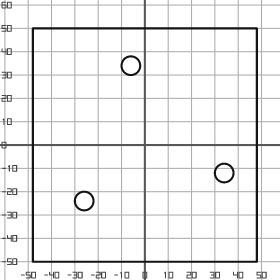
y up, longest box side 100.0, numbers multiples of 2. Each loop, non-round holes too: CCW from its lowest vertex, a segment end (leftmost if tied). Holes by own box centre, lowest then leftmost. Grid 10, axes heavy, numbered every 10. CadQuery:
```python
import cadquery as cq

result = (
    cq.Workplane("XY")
    .moveTo(-48.0, -50.0)
    .lineTo(48.0, -50.0)
    .lineTo(48.0, 50.0)
    .lineTo(-48.0, 50.0)
    .close()
    .moveTo(-26.0, -24.0)
    .circle(4.0)
    .moveTo(34.0, -12.0)
    .circle(4.0)
    .moveTo(-6.0, 34.0)
    .circle(4.0)
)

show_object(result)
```